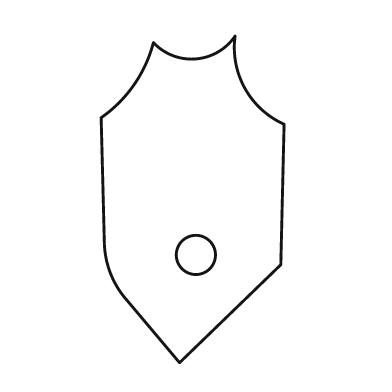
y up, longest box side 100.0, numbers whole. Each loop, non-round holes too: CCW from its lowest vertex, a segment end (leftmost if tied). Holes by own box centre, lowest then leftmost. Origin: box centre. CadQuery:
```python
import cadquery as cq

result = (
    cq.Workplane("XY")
    .moveTo(-4.0, -50.0)
    .lineTo(27.0, -20.0)
    .lineTo(28.0, 23.0)
    .threePointArc((16.0, 34.0), (13.0, 50.0))
    .threePointArc((1.0, 43.0), (-12.0, 48.0))
    .threePointArc((-18.0, 35.0), (-28.0, 25.0))
    .lineTo(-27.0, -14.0)
    .threePointArc((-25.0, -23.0), (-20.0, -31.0))
    .close()
    .moveTo(1.0, -17.0)
    .circle(6.0)
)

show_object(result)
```